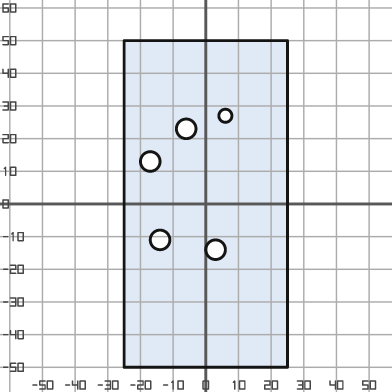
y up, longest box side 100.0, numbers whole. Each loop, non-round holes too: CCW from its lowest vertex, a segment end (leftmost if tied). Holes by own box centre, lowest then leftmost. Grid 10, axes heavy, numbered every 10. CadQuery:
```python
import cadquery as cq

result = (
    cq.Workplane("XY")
    .moveTo(-25.0, -50.0)
    .lineTo(25.0, -50.0)
    .lineTo(25.0, 50.0)
    .lineTo(-25.0, 50.0)
    .close()
    .moveTo(3.0, -14.0)
    .circle(3.0)
    .moveTo(-14.0, -11.0)
    .circle(3.0)
    .moveTo(-17.0, 13.0)
    .circle(3.0)
    .moveTo(-6.0, 23.0)
    .circle(3.0)
    .moveTo(6.0, 27.0)
    .circle(2.0)
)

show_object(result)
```